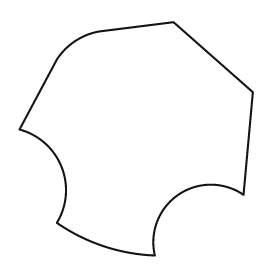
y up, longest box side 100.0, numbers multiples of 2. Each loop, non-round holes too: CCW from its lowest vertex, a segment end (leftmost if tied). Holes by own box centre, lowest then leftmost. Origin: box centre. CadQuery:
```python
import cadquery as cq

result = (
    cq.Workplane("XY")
    .moveTo(8.0, -50.0)
    .threePointArc((18.0, -24.0), (46.0, -24.0))
    .lineTo(50.0, 20.0)
    .lineTo(16.0, 50.0)
    .lineTo(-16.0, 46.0)
    .threePointArc((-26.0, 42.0), (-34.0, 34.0))
    .lineTo(-50.0, 4.0)
    .threePointArc((-32.0, -12.0), (-34.0, -36.0))
    .threePointArc((-14.0, -46.0), (8.0, -50.0))
    .close()
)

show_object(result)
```